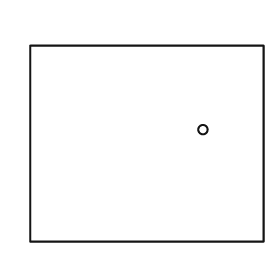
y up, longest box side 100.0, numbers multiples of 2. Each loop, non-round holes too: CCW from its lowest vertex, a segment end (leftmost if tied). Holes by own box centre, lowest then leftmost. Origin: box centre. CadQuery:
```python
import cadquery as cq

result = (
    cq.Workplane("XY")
    .moveTo(-50.0, -42.0)
    .lineTo(50.0, -42.0)
    .lineTo(50.0, 42.0)
    .lineTo(-50.0, 42.0)
    .close()
    .moveTo(24.0, 6.0)
    .circle(2.0)
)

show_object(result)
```